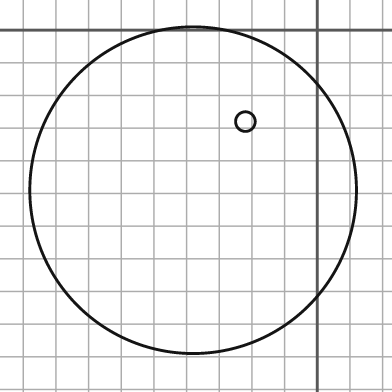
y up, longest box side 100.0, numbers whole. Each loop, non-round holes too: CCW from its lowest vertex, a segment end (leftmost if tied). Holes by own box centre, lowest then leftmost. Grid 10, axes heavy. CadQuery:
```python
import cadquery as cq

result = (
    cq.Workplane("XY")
    .moveTo(-38.0, -49.0)
    .circle(50.0)
    .moveTo(-22.0, -28.0)
    .circle(3.0)
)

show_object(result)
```